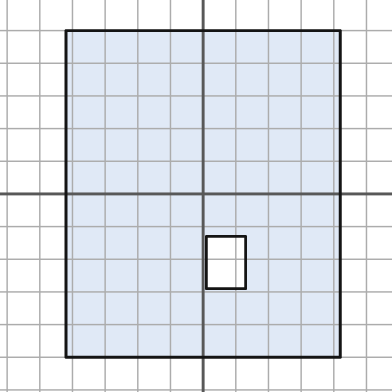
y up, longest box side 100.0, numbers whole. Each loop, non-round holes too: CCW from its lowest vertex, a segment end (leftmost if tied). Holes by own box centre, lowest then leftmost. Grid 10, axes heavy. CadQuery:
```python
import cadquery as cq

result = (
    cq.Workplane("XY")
    .moveTo(-42.0, -50.0)
    .lineTo(42.0, -50.0)
    .lineTo(42.0, 50.0)
    .lineTo(-42.0, 50.0)
    .close()
    .moveTo(1.0, -29.0)
    .lineTo(13.0, -29.0)
    .lineTo(13.0, -13.0)
    .lineTo(1.0, -13.0)
    .close()
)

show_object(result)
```